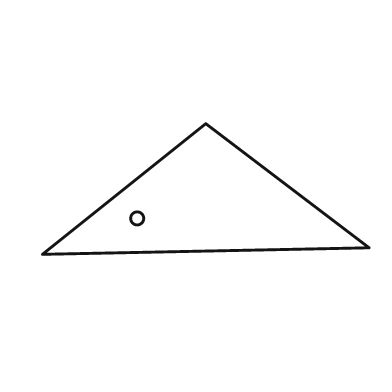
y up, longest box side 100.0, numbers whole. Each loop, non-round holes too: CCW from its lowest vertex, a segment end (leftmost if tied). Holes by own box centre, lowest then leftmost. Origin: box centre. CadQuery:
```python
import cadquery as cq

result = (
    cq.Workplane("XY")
    .moveTo(-50.0, -20.0)
    .lineTo(50.0, -18.0)
    .lineTo(0.0, 20.0)
    .close()
    .moveTo(-21.0, -9.0)
    .circle(2.0)
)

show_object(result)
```